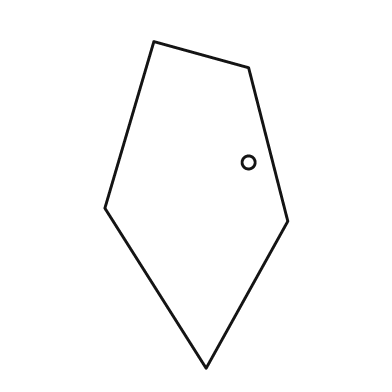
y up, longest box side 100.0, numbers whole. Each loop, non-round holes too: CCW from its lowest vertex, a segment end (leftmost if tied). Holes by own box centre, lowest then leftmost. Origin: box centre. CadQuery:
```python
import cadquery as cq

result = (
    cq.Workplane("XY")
    .moveTo(3.0, -50.0)
    .lineTo(28.0, -5.0)
    .lineTo(16.0, 42.0)
    .lineTo(-13.0, 50.0)
    .lineTo(-28.0, -1.0)
    .close()
    .moveTo(16.0, 13.0)
    .circle(2.0)
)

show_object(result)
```